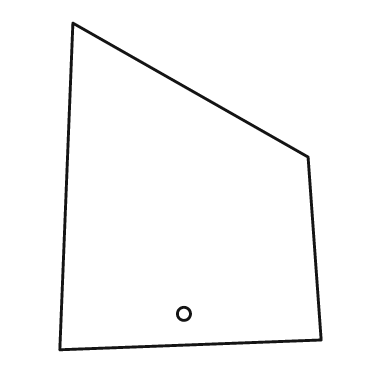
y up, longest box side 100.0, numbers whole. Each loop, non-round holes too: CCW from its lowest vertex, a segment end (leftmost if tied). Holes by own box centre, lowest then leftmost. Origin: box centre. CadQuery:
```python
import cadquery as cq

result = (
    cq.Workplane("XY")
    .moveTo(-40.0, -50.0)
    .lineTo(40.0, -47.0)
    .lineTo(36.0, 9.0)
    .lineTo(-36.0, 50.0)
    .close()
    .moveTo(-2.0, -39.0)
    .circle(2.0)
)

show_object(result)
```